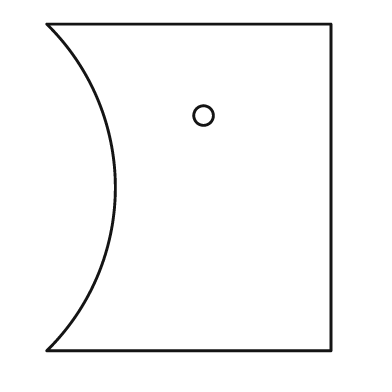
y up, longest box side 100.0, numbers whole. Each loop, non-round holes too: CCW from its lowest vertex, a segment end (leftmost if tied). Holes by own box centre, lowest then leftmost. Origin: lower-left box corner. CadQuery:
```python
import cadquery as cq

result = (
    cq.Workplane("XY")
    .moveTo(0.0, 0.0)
    .lineTo(87.0, 0.0)
    .lineTo(87.0, 100.0)
    .lineTo(0.0, 100.0)
    .threePointArc((21.0, 50.0), (0.0, 0.0))
    .close()
    .moveTo(48.0, 72.0)
    .circle(3.0)
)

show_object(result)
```